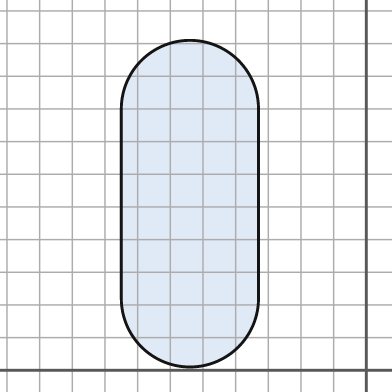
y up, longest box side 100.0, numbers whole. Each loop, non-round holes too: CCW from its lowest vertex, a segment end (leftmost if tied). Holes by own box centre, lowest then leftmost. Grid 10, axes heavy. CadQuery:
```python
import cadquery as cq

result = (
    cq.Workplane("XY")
    .moveTo(-75.0, 22.0)
    .threePointArc((-54.0, 1.0), (-33.0, 22.0))
    .lineTo(-33.0, 80.0)
    .threePointArc((-54.0, 101.0), (-75.0, 80.0))
    .close()
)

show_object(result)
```